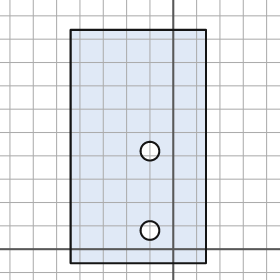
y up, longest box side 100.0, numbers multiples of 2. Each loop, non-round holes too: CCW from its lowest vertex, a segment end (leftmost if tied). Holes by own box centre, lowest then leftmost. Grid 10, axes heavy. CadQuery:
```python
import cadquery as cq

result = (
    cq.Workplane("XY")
    .moveTo(-44.0, -6.0)
    .lineTo(14.0, -6.0)
    .lineTo(14.0, 94.0)
    .lineTo(-44.0, 94.0)
    .close()
    .moveTo(-10.0, 8.0)
    .circle(4.0)
    .moveTo(-10.0, 42.0)
    .circle(4.0)
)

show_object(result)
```